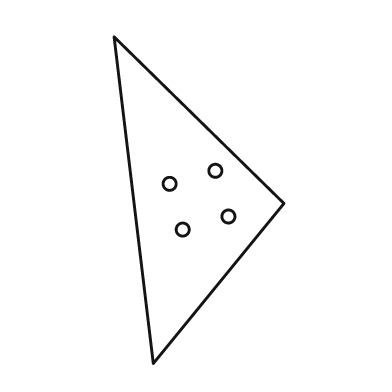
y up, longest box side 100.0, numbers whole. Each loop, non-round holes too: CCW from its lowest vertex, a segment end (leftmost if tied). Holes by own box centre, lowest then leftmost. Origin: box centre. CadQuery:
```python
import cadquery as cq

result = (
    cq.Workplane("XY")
    .moveTo(-14.0, -50.0)
    .lineTo(26.0, -1.0)
    .lineTo(-26.0, 50.0)
    .close()
    .moveTo(-5.0, -9.0)
    .circle(2.0)
    .moveTo(9.0, -5.0)
    .circle(2.0)
    .moveTo(-9.0, 5.0)
    .circle(2.0)
    .moveTo(5.0, 9.0)
    .circle(2.0)
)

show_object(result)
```